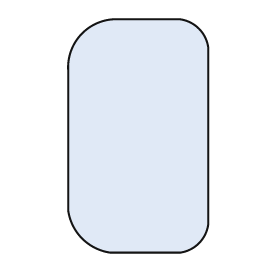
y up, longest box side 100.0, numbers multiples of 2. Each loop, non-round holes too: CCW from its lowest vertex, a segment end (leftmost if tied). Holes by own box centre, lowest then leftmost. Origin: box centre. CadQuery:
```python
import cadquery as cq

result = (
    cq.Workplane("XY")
    .moveTo(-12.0, -50.0)
    .lineTo(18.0, -50.0)
    .threePointArc((26.0, -46.0), (30.0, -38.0))
    .lineTo(30.0, 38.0)
    .threePointArc((26.0, 46.0), (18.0, 50.0))
    .lineTo(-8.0, 50.0)
    .threePointArc((-24.0, 44.0), (-30.0, 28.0))
    .lineTo(-30.0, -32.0)
    .threePointArc((-24.0, -44.0), (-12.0, -50.0))
    .close()
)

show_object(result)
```